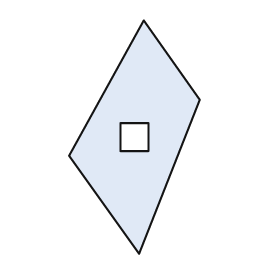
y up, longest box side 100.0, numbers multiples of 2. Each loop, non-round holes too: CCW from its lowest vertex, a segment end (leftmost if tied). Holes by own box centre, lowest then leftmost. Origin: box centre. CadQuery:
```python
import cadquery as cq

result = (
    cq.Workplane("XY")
    .moveTo(2.0, -50.0)
    .lineTo(28.0, 16.0)
    .lineTo(4.0, 50.0)
    .lineTo(-28.0, -8.0)
    .close()
    .moveTo(-6.0, -6.0)
    .lineTo(6.0, -6.0)
    .lineTo(6.0, 6.0)
    .lineTo(-6.0, 6.0)
    .close()
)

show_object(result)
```